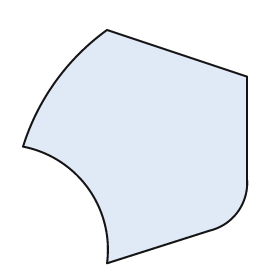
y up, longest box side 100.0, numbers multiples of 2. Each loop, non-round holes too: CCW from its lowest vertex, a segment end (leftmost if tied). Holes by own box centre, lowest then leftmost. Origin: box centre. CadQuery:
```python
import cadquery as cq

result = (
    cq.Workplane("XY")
    .moveTo(-12.0, -50.0)
    .lineTo(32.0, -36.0)
    .threePointArc((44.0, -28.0), (48.0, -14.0))
    .lineTo(48.0, 30.0)
    .lineTo(-12.0, 50.0)
    .threePointArc((-34.0, 28.0), (-48.0, 0.0))
    .threePointArc((-20.0, -18.0), (-12.0, -50.0))
    .close()
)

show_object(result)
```